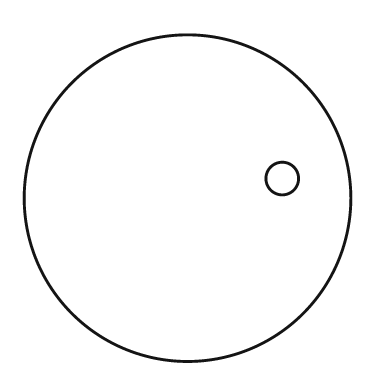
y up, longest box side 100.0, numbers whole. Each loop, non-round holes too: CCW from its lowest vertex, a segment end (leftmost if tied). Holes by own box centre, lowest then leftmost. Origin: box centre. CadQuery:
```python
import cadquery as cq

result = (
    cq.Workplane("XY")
    .moveTo(0.0, 0.0)
    .circle(50.0)
    .moveTo(29.0, 6.0)
    .circle(5.0)
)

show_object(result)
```